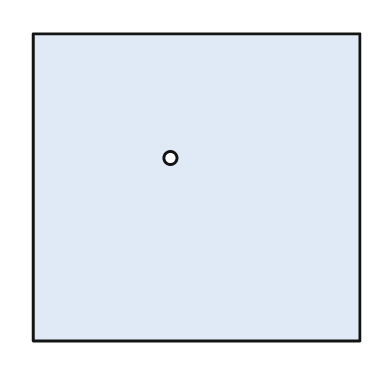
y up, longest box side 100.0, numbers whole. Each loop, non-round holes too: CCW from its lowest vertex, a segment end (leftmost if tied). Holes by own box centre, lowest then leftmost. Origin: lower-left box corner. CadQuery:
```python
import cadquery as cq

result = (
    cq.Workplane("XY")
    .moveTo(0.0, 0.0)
    .lineTo(100.0, 0.0)
    .lineTo(100.0, 94.0)
    .lineTo(0.0, 94.0)
    .close()
    .moveTo(42.0, 56.0)
    .circle(2.0)
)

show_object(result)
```